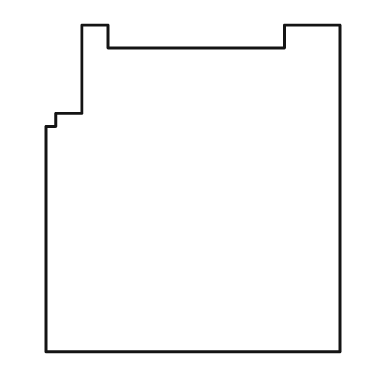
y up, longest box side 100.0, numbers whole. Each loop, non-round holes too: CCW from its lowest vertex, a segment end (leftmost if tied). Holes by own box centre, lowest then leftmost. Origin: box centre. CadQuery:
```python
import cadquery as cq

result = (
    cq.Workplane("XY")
    .moveTo(-45.0, -50.0)
    .lineTo(45.0, -50.0)
    .lineTo(45.0, 50.0)
    .lineTo(28.0, 50.0)
    .lineTo(28.0, 43.0)
    .lineTo(-26.0, 43.0)
    .lineTo(-26.0, 50.0)
    .lineTo(-34.0, 50.0)
    .lineTo(-34.0, 23.0)
    .lineTo(-42.0, 23.0)
    .lineTo(-42.0, 19.0)
    .lineTo(-45.0, 19.0)
    .close()
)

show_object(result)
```